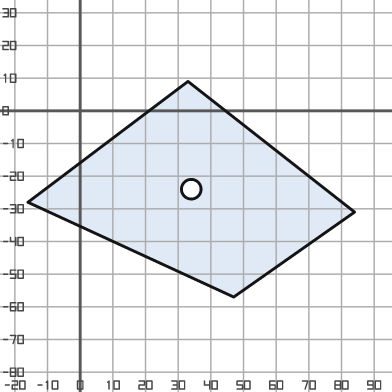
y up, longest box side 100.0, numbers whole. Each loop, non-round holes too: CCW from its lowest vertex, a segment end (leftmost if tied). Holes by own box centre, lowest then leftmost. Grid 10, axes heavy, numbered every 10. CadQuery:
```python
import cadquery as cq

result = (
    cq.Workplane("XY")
    .moveTo(47.0, -57.0)
    .lineTo(84.0, -31.0)
    .lineTo(33.0, 9.0)
    .lineTo(-16.0, -28.0)
    .close()
    .moveTo(34.0, -24.0)
    .circle(3.0)
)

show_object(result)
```